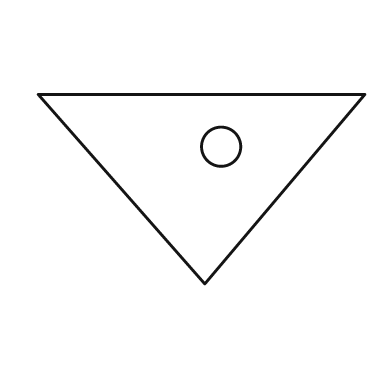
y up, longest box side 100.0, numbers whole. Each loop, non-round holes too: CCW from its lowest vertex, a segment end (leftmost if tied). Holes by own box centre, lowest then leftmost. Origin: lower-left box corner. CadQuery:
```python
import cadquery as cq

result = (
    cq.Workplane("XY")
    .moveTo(51.0, 0.0)
    .lineTo(100.0, 58.0)
    .lineTo(0.0, 58.0)
    .close()
    .moveTo(56.0, 42.0)
    .circle(6.0)
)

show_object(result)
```